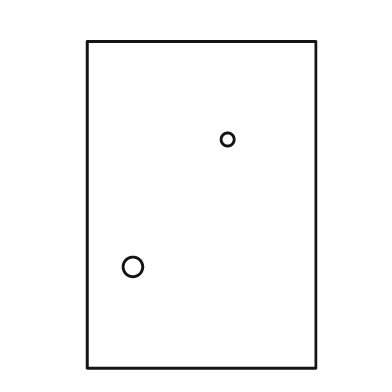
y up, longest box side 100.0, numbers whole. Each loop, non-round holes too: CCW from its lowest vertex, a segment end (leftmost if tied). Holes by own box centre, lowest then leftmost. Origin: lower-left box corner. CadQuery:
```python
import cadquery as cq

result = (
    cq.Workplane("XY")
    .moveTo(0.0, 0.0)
    .lineTo(70.0, 0.0)
    .lineTo(70.0, 100.0)
    .lineTo(0.0, 100.0)
    .close()
    .moveTo(14.0, 31.0)
    .circle(3.0)
    .moveTo(43.0, 70.0)
    .circle(2.0)
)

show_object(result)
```